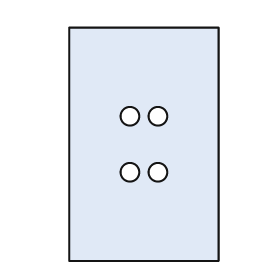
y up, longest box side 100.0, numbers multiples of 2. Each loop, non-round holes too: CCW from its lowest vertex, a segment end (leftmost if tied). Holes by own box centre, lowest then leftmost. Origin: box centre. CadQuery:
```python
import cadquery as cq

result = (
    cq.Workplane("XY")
    .moveTo(-32.0, -50.0)
    .lineTo(32.0, -50.0)
    .lineTo(32.0, 50.0)
    .lineTo(-32.0, 50.0)
    .close()
    .moveTo(-6.0, -12.0)
    .circle(4.0)
    .moveTo(6.0, -12.0)
    .circle(4.0)
    .moveTo(-6.0, 12.0)
    .circle(4.0)
    .moveTo(6.0, 12.0)
    .circle(4.0)
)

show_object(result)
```